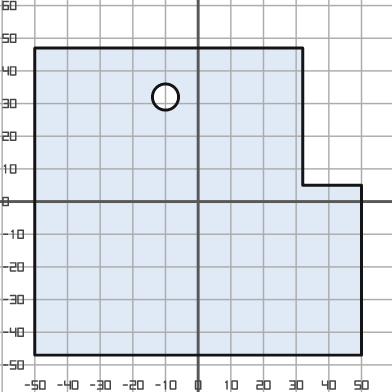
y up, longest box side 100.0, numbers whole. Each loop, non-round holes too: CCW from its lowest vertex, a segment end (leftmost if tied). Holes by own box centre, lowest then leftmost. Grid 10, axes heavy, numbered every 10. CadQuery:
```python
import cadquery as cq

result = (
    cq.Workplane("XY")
    .moveTo(-50.0, -47.0)
    .lineTo(50.0, -47.0)
    .lineTo(50.0, 5.0)
    .lineTo(32.0, 5.0)
    .lineTo(32.0, 47.0)
    .lineTo(-50.0, 47.0)
    .close()
    .moveTo(-10.0, 32.0)
    .circle(4.0)
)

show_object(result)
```